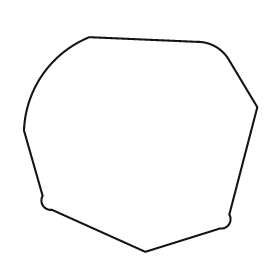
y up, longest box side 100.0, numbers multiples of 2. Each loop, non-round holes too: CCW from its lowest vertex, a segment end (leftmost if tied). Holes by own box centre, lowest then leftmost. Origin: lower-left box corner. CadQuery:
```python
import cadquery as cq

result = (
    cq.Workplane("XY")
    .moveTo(52.0, 0.0)
    .lineTo(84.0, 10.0)
    .threePointArc((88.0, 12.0), (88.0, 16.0))
    .lineTo(100.0, 62.0)
    .lineTo(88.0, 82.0)
    .threePointArc((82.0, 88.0), (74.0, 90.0))
    .lineTo(28.0, 92.0)
    .threePointArc((8.0, 76.0), (0.0, 52.0))
    .lineTo(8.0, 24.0)
    .threePointArc((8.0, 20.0), (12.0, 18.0))
    .close()
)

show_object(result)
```